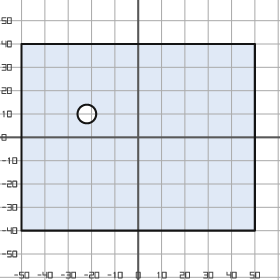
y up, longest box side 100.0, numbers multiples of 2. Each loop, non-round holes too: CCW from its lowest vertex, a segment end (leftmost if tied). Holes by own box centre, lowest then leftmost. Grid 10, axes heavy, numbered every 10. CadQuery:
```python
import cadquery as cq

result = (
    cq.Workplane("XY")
    .moveTo(-50.0, -40.0)
    .lineTo(50.0, -40.0)
    .lineTo(50.0, 40.0)
    .lineTo(-50.0, 40.0)
    .close()
    .moveTo(-22.0, 10.0)
    .circle(4.0)
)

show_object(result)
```